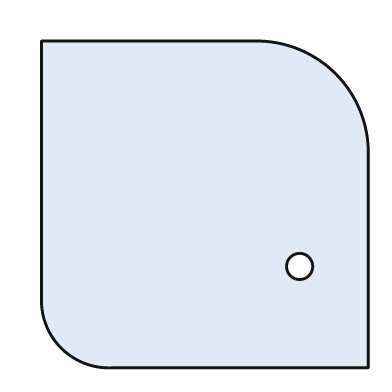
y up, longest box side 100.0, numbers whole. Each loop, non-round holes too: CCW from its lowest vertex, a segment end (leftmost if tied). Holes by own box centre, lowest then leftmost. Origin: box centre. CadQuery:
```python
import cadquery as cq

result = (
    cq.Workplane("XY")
    .moveTo(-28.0, -50.0)
    .lineTo(50.0, -50.0)
    .lineTo(50.0, 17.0)
    .threePointArc((40.0, 40.0), (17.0, 50.0))
    .lineTo(-50.0, 50.0)
    .lineTo(-50.0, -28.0)
    .threePointArc((-44.0, -44.0), (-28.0, -50.0))
    .close()
    .moveTo(29.0, -19.0)
    .circle(4.0)
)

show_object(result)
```